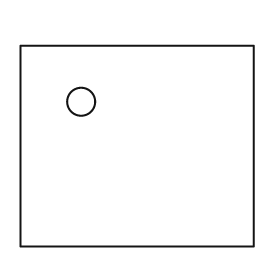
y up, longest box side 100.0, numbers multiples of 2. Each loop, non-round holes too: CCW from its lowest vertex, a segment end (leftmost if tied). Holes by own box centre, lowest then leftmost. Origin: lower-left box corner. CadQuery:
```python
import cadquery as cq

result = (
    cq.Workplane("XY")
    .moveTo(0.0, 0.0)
    .lineTo(100.0, 0.0)
    .lineTo(100.0, 86.0)
    .lineTo(0.0, 86.0)
    .close()
    .moveTo(26.0, 62.0)
    .circle(6.0)
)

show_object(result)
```